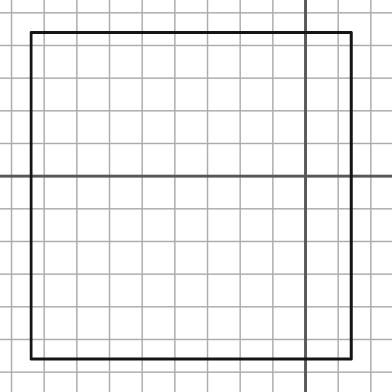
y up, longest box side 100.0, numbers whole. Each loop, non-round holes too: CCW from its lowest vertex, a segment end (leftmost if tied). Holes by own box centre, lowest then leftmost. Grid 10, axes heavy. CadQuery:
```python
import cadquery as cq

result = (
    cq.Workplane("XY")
    .moveTo(-84.0, -56.0)
    .lineTo(14.0, -56.0)
    .lineTo(14.0, 44.0)
    .lineTo(-84.0, 44.0)
    .close()
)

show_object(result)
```